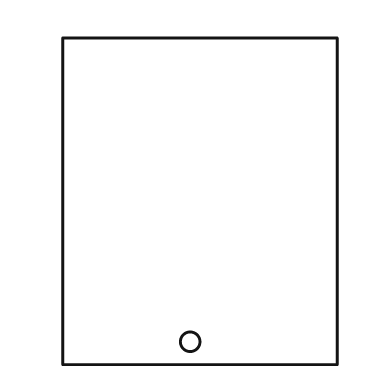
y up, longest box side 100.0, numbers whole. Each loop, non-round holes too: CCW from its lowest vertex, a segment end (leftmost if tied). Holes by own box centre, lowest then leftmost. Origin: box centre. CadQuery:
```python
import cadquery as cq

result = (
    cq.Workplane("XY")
    .moveTo(-42.0, -50.0)
    .lineTo(42.0, -50.0)
    .lineTo(42.0, 50.0)
    .lineTo(-42.0, 50.0)
    .close()
    .moveTo(-3.0, -43.0)
    .circle(3.0)
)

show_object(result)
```